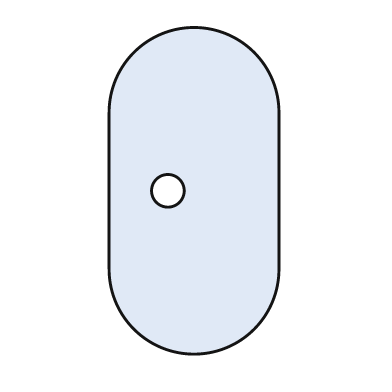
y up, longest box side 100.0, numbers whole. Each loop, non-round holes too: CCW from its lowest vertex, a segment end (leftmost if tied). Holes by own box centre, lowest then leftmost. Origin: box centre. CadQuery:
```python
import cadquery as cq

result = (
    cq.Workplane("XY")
    .moveTo(-26.0, -24.0)
    .threePointArc((0.0, -50.0), (26.0, -24.0))
    .lineTo(26.0, 24.0)
    .threePointArc((0.0, 50.0), (-26.0, 24.0))
    .close()
    .moveTo(-8.0, 0.0)
    .circle(5.0)
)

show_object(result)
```